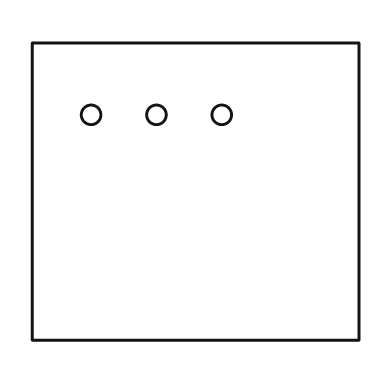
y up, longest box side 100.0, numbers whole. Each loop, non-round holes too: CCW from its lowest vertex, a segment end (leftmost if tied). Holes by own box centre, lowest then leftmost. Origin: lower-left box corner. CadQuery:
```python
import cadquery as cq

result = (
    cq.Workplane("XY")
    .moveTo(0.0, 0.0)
    .lineTo(100.0, 0.0)
    .lineTo(100.0, 91.0)
    .lineTo(0.0, 91.0)
    .close()
    .moveTo(18.0, 69.0)
    .circle(3.0)
    .moveTo(38.0, 69.0)
    .circle(3.0)
    .moveTo(58.0, 69.0)
    .circle(3.0)
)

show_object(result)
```